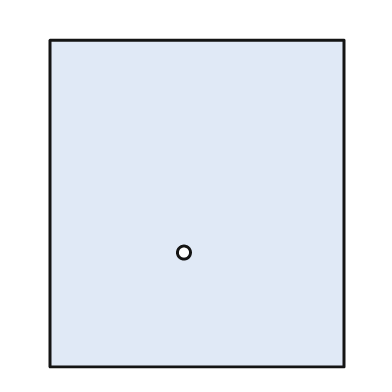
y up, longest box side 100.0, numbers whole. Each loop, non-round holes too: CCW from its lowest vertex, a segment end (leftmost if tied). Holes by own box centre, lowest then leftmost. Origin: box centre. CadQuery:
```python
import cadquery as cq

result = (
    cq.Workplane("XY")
    .moveTo(-45.0, -50.0)
    .lineTo(45.0, -50.0)
    .lineTo(45.0, 50.0)
    .lineTo(-45.0, 50.0)
    .close()
    .moveTo(-4.0, -15.0)
    .circle(2.0)
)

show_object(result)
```